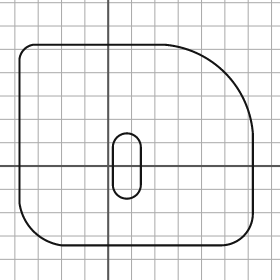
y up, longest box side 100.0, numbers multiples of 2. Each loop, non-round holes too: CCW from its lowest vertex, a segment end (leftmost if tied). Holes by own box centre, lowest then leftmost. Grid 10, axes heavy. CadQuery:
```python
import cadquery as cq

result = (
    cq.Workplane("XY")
    .moveTo(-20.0, -34.0)
    .lineTo(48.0, -34.0)
    .threePointArc((58.0, -30.0), (62.0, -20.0))
    .lineTo(62.0, 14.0)
    .threePointArc((50.0, 40.0), (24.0, 52.0))
    .lineTo(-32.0, 52.0)
    .threePointArc((-36.0, 50.0), (-38.0, 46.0))
    .lineTo(-38.0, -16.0)
    .threePointArc((-32.0, -28.0), (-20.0, -34.0))
    .close()
    .moveTo(2.0, -8.0)
    .threePointArc((8.0, -14.0), (14.0, -8.0))
    .lineTo(14.0, 8.0)
    .threePointArc((8.0, 14.0), (2.0, 8.0))
    .close()
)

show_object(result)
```